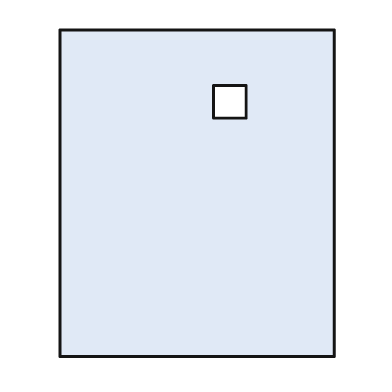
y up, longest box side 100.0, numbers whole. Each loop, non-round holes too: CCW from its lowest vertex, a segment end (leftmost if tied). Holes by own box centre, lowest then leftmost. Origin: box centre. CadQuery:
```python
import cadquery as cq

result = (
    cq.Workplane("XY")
    .moveTo(-42.0, -50.0)
    .lineTo(42.0, -50.0)
    .lineTo(42.0, 50.0)
    .lineTo(-42.0, 50.0)
    .close()
    .moveTo(5.0, 23.0)
    .lineTo(15.0, 23.0)
    .lineTo(15.0, 33.0)
    .lineTo(5.0, 33.0)
    .close()
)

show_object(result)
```